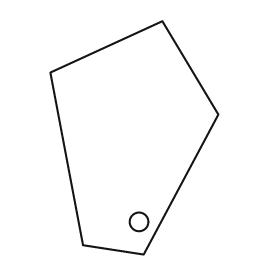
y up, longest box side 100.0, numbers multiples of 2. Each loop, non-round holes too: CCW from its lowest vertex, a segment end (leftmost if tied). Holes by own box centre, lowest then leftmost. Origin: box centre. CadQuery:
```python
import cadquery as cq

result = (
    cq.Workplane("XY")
    .moveTo(4.0, -50.0)
    .lineTo(36.0, 10.0)
    .lineTo(12.0, 50.0)
    .lineTo(-36.0, 28.0)
    .lineTo(-22.0, -46.0)
    .close()
    .moveTo(2.0, -36.0)
    .circle(4.0)
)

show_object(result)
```